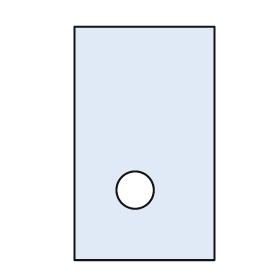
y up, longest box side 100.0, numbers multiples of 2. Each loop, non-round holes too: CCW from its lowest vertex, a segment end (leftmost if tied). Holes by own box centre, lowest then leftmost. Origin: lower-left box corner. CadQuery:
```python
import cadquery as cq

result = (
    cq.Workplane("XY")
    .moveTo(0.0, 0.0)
    .lineTo(60.0, 0.0)
    .lineTo(60.0, 100.0)
    .lineTo(0.0, 100.0)
    .close()
    .moveTo(26.0, 30.0)
    .circle(8.0)
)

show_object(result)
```